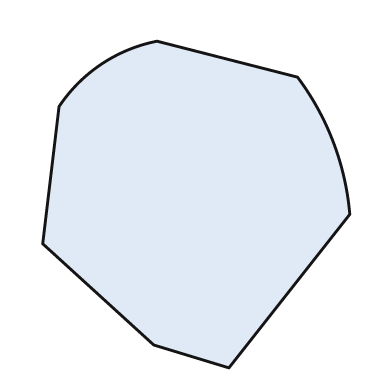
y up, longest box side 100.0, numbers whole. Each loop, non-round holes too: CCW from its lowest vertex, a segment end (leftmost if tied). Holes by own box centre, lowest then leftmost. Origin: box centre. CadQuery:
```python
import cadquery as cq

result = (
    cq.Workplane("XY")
    .moveTo(10.0, -50.0)
    .lineTo(47.0, -3.0)
    .threePointArc((42.0, 19.0), (31.0, 39.0))
    .lineTo(-12.0, 50.0)
    .threePointArc((-29.0, 43.0), (-42.0, 30.0))
    .lineTo(-47.0, -12.0)
    .lineTo(-13.0, -43.0)
    .close()
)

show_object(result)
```